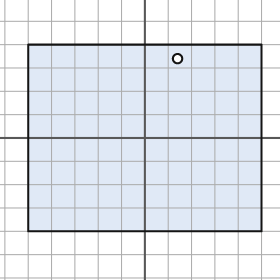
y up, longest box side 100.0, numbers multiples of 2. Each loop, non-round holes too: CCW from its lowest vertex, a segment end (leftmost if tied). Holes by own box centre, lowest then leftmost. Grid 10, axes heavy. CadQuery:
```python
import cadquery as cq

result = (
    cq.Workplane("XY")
    .moveTo(-50.0, -40.0)
    .lineTo(50.0, -40.0)
    .lineTo(50.0, 40.0)
    .lineTo(-50.0, 40.0)
    .close()
    .moveTo(14.0, 34.0)
    .circle(2.0)
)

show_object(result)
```